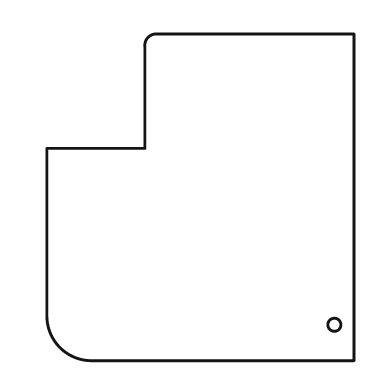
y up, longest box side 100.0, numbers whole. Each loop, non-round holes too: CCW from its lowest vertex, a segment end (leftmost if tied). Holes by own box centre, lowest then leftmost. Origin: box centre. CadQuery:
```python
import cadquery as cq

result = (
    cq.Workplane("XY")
    .moveTo(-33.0, -50.0)
    .lineTo(47.0, -50.0)
    .lineTo(47.0, 50.0)
    .lineTo(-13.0, 50.0)
    .threePointArc((-16.0, 49.0), (-17.0, 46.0))
    .lineTo(-17.0, 15.0)
    .lineTo(-47.0, 15.0)
    .lineTo(-47.0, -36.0)
    .threePointArc((-43.0, -46.0), (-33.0, -50.0))
    .close()
    .moveTo(41.0, -39.0)
    .circle(2.0)
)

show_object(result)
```